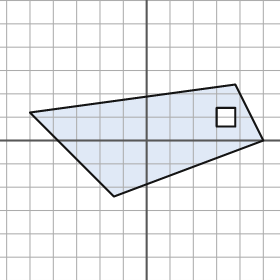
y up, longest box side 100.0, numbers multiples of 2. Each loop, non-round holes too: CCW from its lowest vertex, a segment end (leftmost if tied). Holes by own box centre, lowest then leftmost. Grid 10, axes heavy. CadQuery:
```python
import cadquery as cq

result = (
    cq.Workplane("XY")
    .moveTo(-14.0, -24.0)
    .lineTo(50.0, 0.0)
    .lineTo(38.0, 24.0)
    .lineTo(-50.0, 12.0)
    .close()
    .moveTo(30.0, 6.0)
    .lineTo(38.0, 6.0)
    .lineTo(38.0, 14.0)
    .lineTo(30.0, 14.0)
    .close()
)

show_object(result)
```